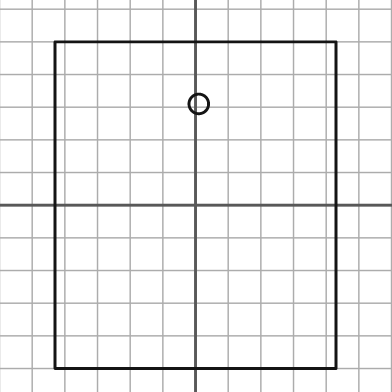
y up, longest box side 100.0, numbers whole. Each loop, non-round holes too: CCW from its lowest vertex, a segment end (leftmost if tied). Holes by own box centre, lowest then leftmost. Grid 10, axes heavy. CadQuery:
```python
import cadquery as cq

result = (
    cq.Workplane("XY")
    .moveTo(-43.0, -50.0)
    .lineTo(43.0, -50.0)
    .lineTo(43.0, 50.0)
    .lineTo(-43.0, 50.0)
    .close()
    .moveTo(1.0, 31.0)
    .circle(3.0)
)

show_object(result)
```